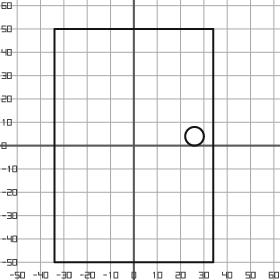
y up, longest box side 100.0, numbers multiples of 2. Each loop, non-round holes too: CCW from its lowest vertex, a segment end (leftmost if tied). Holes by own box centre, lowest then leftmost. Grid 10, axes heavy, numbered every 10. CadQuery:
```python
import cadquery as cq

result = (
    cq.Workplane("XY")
    .moveTo(-34.0, -50.0)
    .lineTo(34.0, -50.0)
    .lineTo(34.0, 50.0)
    .lineTo(-34.0, 50.0)
    .close()
    .moveTo(26.0, 4.0)
    .circle(4.0)
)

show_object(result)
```